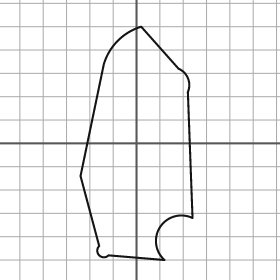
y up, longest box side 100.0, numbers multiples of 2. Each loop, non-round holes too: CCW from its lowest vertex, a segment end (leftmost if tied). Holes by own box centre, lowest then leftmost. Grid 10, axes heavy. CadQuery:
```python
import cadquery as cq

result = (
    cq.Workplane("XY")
    .moveTo(12.0, -50.0)
    .threePointArc((10.0, -36.0), (24.0, -32.0))
    .lineTo(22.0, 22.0)
    .threePointArc((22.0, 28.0), (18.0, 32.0))
    .lineTo(2.0, 50.0)
    .threePointArc((-8.0, 44.0), (-14.0, 34.0))
    .lineTo(-24.0, -14.0)
    .lineTo(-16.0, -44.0)
    .threePointArc((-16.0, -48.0), (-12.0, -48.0))
    .close()
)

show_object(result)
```